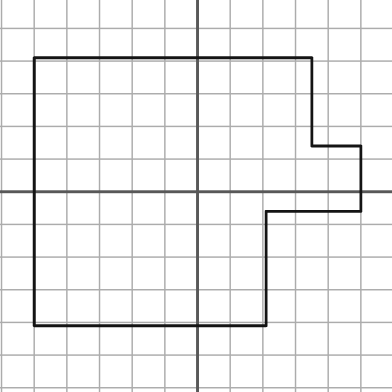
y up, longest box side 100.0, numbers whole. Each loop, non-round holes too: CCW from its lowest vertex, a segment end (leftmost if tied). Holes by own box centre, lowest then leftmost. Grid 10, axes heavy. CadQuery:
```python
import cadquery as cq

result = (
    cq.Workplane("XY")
    .moveTo(-50.0, -41.0)
    .lineTo(21.0, -41.0)
    .lineTo(21.0, -6.0)
    .lineTo(50.0, -6.0)
    .lineTo(50.0, 14.0)
    .lineTo(35.0, 14.0)
    .lineTo(35.0, 41.0)
    .lineTo(-50.0, 41.0)
    .close()
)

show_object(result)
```